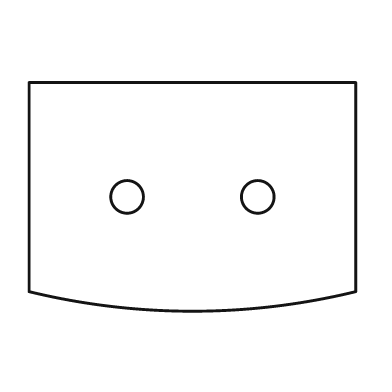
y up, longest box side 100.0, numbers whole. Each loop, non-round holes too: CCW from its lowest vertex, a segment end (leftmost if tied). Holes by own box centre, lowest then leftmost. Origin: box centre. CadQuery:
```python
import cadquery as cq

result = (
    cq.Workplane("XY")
    .moveTo(-50.0, -29.0)
    .threePointArc((0.0, -35.0), (50.0, -29.0))
    .lineTo(50.0, 35.0)
    .lineTo(-50.0, 35.0)
    .close()
    .moveTo(-20.0, 0.0)
    .circle(5.0)
    .moveTo(20.0, 0.0)
    .circle(5.0)
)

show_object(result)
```